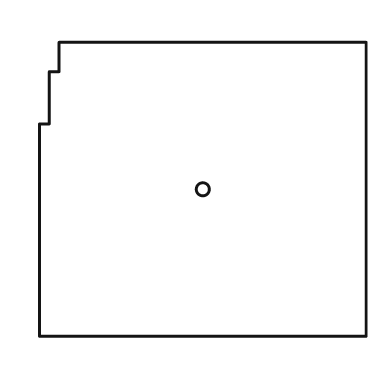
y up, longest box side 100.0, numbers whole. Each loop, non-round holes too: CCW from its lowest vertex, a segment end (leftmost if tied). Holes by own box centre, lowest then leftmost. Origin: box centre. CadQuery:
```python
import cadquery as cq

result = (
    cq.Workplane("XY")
    .moveTo(-50.0, -45.0)
    .lineTo(50.0, -45.0)
    .lineTo(50.0, 45.0)
    .lineTo(-44.0, 45.0)
    .lineTo(-44.0, 36.0)
    .lineTo(-47.0, 36.0)
    .lineTo(-47.0, 20.0)
    .lineTo(-50.0, 20.0)
    .close()
    .moveTo(0.0, 0.0)
    .circle(2.0)
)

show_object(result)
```